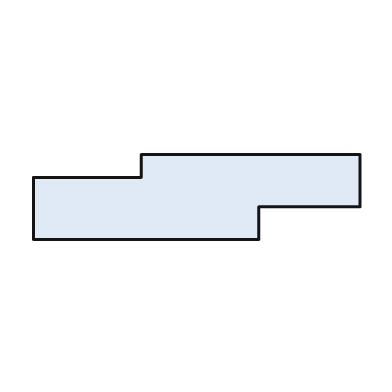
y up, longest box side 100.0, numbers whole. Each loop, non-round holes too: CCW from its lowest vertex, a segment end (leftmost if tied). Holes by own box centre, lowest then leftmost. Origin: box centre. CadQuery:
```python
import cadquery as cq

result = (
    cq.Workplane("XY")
    .moveTo(-50.0, -13.0)
    .lineTo(19.0, -13.0)
    .lineTo(19.0, -3.0)
    .lineTo(50.0, -3.0)
    .lineTo(50.0, 13.0)
    .lineTo(-17.0, 13.0)
    .lineTo(-17.0, 6.0)
    .lineTo(-50.0, 6.0)
    .close()
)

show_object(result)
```